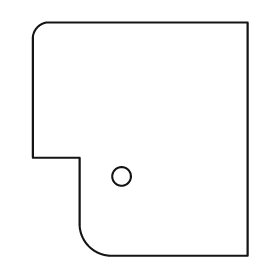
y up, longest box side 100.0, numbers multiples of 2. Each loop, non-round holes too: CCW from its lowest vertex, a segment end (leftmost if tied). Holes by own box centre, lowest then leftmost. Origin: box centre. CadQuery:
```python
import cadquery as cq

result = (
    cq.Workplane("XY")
    .moveTo(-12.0, -50.0)
    .lineTo(46.0, -50.0)
    .lineTo(46.0, 50.0)
    .lineTo(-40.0, 50.0)
    .threePointArc((-44.0, 48.0), (-46.0, 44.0))
    .lineTo(-46.0, -8.0)
    .lineTo(-26.0, -8.0)
    .lineTo(-26.0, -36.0)
    .threePointArc((-22.0, -46.0), (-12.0, -50.0))
    .close()
    .moveTo(-8.0, -16.0)
    .circle(4.0)
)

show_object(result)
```